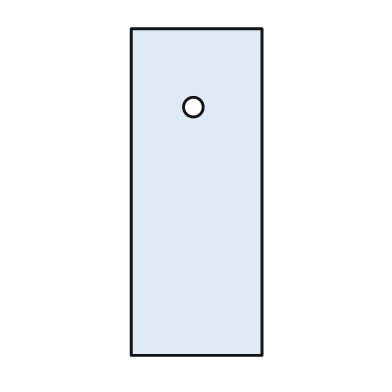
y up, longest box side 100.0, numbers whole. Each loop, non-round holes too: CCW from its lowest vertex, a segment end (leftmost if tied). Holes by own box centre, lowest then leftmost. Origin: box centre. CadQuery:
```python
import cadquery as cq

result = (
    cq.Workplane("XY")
    .moveTo(-20.0, -50.0)
    .lineTo(20.0, -50.0)
    .lineTo(20.0, 50.0)
    .lineTo(-20.0, 50.0)
    .close()
    .moveTo(-1.0, 26.0)
    .circle(3.0)
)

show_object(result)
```